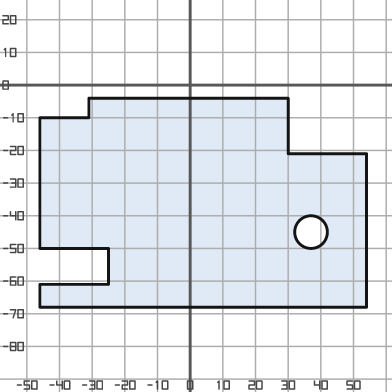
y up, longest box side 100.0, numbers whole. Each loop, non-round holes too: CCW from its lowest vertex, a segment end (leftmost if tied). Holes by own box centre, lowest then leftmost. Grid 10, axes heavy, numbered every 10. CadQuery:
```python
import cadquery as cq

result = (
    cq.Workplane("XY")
    .moveTo(-46.0, -68.0)
    .lineTo(54.0, -68.0)
    .lineTo(54.0, -21.0)
    .lineTo(30.0, -21.0)
    .lineTo(30.0, -4.0)
    .lineTo(-31.0, -4.0)
    .lineTo(-31.0, -10.0)
    .lineTo(-46.0, -10.0)
    .lineTo(-46.0, -50.0)
    .lineTo(-25.0, -50.0)
    .lineTo(-25.0, -61.0)
    .lineTo(-46.0, -61.0)
    .close()
    .moveTo(37.0, -45.0)
    .circle(5.0)
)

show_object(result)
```